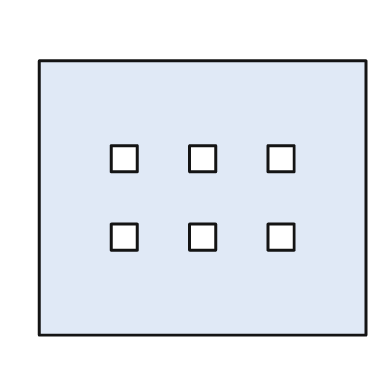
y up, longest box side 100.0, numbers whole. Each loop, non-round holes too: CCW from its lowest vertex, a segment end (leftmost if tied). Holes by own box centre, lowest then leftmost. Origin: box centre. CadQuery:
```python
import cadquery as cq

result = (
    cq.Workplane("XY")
    .moveTo(-50.0, -42.0)
    .lineTo(50.0, -42.0)
    .lineTo(50.0, 42.0)
    .lineTo(-50.0, 42.0)
    .close()
    .moveTo(-28.0, -16.0)
    .lineTo(-20.0, -16.0)
    .lineTo(-20.0, -8.0)
    .lineTo(-28.0, -8.0)
    .close()
    .moveTo(-4.0, -16.0)
    .lineTo(4.0, -16.0)
    .lineTo(4.0, -8.0)
    .lineTo(-4.0, -8.0)
    .close()
    .moveTo(20.0, -16.0)
    .lineTo(28.0, -16.0)
    .lineTo(28.0, -8.0)
    .lineTo(20.0, -8.0)
    .close()
    .moveTo(-28.0, 8.0)
    .lineTo(-20.0, 8.0)
    .lineTo(-20.0, 16.0)
    .lineTo(-28.0, 16.0)
    .close()
    .moveTo(-4.0, 8.0)
    .lineTo(4.0, 8.0)
    .lineTo(4.0, 16.0)
    .lineTo(-4.0, 16.0)
    .close()
    .moveTo(20.0, 8.0)
    .lineTo(28.0, 8.0)
    .lineTo(28.0, 16.0)
    .lineTo(20.0, 16.0)
    .close()
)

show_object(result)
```